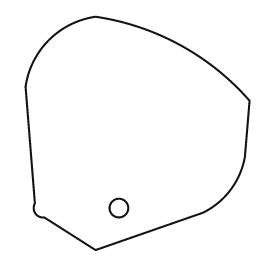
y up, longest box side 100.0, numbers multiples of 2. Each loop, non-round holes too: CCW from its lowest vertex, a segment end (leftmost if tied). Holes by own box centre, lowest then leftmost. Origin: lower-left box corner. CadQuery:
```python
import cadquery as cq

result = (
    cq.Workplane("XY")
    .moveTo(30.0, 0.0)
    .lineTo(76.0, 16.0)
    .threePointArc((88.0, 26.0), (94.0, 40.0))
    .lineTo(96.0, 64.0)
    .threePointArc((66.0, 88.0), (30.0, 100.0))
    .threePointArc((10.0, 90.0), (0.0, 70.0))
    .lineTo(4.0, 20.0)
    .threePointArc((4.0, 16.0), (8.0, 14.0))
    .close()
    .moveTo(40.0, 18.0)
    .circle(4.0)
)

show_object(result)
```